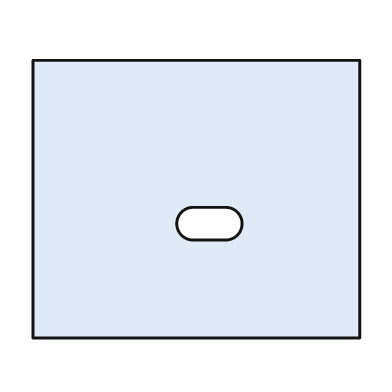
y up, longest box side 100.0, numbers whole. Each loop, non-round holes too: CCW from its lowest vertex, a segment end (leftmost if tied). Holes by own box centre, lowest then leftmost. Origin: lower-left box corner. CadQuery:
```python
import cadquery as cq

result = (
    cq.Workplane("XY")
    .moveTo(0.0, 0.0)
    .lineTo(100.0, 0.0)
    .lineTo(100.0, 85.0)
    .lineTo(0.0, 85.0)
    .close()
    .moveTo(49.0, 30.0)
    .lineTo(59.0, 30.0)
    .threePointArc((64.0, 35.0), (59.0, 40.0))
    .lineTo(49.0, 40.0)
    .threePointArc((44.0, 35.0), (49.0, 30.0))
    .close()
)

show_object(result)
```